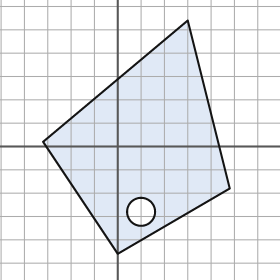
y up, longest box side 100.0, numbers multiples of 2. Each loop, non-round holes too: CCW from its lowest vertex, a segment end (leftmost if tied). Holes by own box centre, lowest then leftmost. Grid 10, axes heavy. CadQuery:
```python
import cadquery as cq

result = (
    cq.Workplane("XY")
    .moveTo(0.0, -46.0)
    .lineTo(48.0, -18.0)
    .lineTo(30.0, 54.0)
    .lineTo(-32.0, 2.0)
    .close()
    .moveTo(10.0, -28.0)
    .circle(6.0)
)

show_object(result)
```